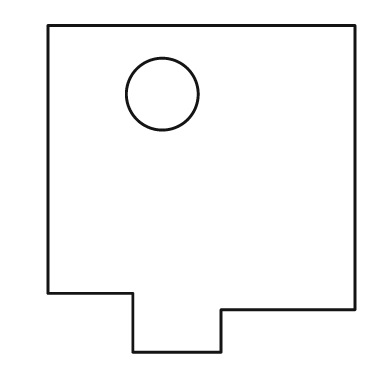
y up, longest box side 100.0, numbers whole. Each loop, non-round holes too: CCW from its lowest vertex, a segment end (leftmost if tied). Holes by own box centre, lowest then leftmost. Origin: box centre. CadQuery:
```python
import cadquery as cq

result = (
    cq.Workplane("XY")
    .moveTo(-21.0, -50.0)
    .lineTo(6.0, -50.0)
    .lineTo(6.0, -37.0)
    .lineTo(47.0, -37.0)
    .lineTo(47.0, 50.0)
    .lineTo(-47.0, 50.0)
    .lineTo(-47.0, -32.0)
    .lineTo(-21.0, -32.0)
    .close()
    .moveTo(-12.0, 29.0)
    .circle(11.0)
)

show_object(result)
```